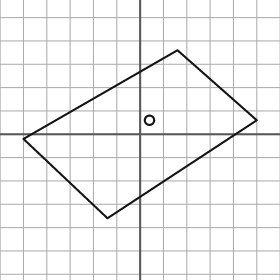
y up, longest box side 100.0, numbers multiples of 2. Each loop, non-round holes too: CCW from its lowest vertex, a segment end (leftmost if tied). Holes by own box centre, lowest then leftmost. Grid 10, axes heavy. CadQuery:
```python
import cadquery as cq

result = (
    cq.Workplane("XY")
    .moveTo(-14.0, -36.0)
    .lineTo(50.0, 6.0)
    .lineTo(16.0, 36.0)
    .lineTo(-50.0, -2.0)
    .close()
    .moveTo(4.0, 6.0)
    .circle(2.0)
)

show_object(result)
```